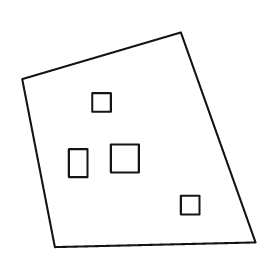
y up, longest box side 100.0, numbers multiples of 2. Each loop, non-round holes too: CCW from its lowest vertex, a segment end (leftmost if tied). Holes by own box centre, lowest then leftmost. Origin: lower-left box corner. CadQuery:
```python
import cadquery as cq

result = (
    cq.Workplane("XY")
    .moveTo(14.0, 0.0)
    .lineTo(100.0, 2.0)
    .lineTo(68.0, 92.0)
    .lineTo(0.0, 72.0)
    .close()
    .moveTo(68.0, 14.0)
    .lineTo(76.0, 14.0)
    .lineTo(76.0, 22.0)
    .lineTo(68.0, 22.0)
    .close()
    .moveTo(20.0, 30.0)
    .lineTo(28.0, 30.0)
    .lineTo(28.0, 42.0)
    .lineTo(20.0, 42.0)
    .close()
    .moveTo(38.0, 32.0)
    .lineTo(50.0, 32.0)
    .lineTo(50.0, 44.0)
    .lineTo(38.0, 44.0)
    .close()
    .moveTo(30.0, 58.0)
    .lineTo(38.0, 58.0)
    .lineTo(38.0, 66.0)
    .lineTo(30.0, 66.0)
    .close()
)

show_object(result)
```